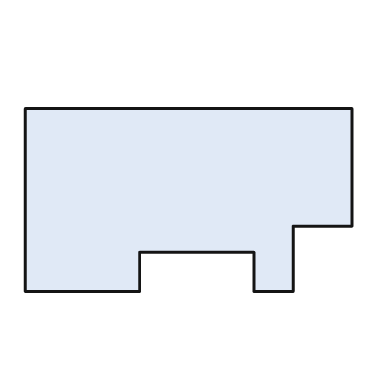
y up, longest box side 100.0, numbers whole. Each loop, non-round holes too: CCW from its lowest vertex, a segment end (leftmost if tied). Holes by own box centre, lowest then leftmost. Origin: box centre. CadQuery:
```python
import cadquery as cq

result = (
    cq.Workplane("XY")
    .moveTo(-50.0, -28.0)
    .lineTo(-15.0, -28.0)
    .lineTo(-15.0, -16.0)
    .lineTo(20.0, -16.0)
    .lineTo(20.0, -28.0)
    .lineTo(32.0, -28.0)
    .lineTo(32.0, -8.0)
    .lineTo(50.0, -8.0)
    .lineTo(50.0, 28.0)
    .lineTo(-50.0, 28.0)
    .close()
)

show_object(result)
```